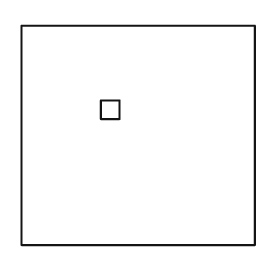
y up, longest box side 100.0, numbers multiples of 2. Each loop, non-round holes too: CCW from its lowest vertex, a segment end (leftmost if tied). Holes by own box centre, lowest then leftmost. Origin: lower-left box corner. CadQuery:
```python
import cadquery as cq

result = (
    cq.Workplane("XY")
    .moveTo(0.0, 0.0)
    .lineTo(100.0, 0.0)
    .lineTo(100.0, 94.0)
    .lineTo(0.0, 94.0)
    .close()
    .moveTo(34.0, 54.0)
    .lineTo(42.0, 54.0)
    .lineTo(42.0, 62.0)
    .lineTo(34.0, 62.0)
    .close()
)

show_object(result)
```